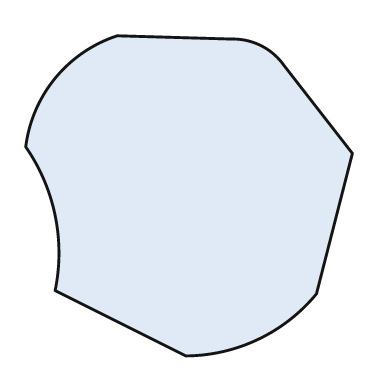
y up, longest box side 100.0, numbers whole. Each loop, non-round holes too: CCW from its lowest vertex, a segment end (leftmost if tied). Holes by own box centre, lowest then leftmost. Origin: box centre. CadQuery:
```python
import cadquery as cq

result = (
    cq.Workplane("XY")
    .moveTo(-1.0, -49.0)
    .threePointArc((21.0, -44.0), (39.0, -30.0))
    .lineTo(50.0, 13.0)
    .lineTo(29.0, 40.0)
    .threePointArc((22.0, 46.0), (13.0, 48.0))
    .lineTo(-22.0, 49.0)
    .threePointArc((-41.0, 36.0), (-50.0, 15.0))
    .threePointArc((-41.0, -6.0), (-41.0, -29.0))
    .close()
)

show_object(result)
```